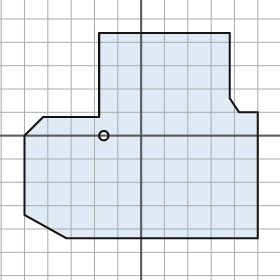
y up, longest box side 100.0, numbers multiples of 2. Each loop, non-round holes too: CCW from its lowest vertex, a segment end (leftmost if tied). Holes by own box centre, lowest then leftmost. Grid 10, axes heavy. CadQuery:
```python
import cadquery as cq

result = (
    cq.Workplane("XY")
    .moveTo(-32.0, -44.0)
    .lineTo(50.0, -44.0)
    .lineTo(50.0, 10.0)
    .lineTo(42.0, 10.0)
    .lineTo(38.0, 16.0)
    .lineTo(38.0, 44.0)
    .lineTo(-18.0, 44.0)
    .lineTo(-18.0, 8.0)
    .lineTo(-42.0, 8.0)
    .lineTo(-50.0, 0.0)
    .lineTo(-50.0, -34.0)
    .close()
    .moveTo(-16.0, 0.0)
    .circle(2.0)
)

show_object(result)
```